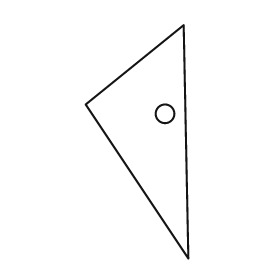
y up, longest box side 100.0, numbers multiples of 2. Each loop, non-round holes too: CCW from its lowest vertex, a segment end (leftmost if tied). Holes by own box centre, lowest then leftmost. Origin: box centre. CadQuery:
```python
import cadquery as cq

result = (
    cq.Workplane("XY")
    .moveTo(22.0, -50.0)
    .lineTo(20.0, 50.0)
    .lineTo(-22.0, 16.0)
    .close()
    .moveTo(12.0, 12.0)
    .circle(4.0)
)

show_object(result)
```